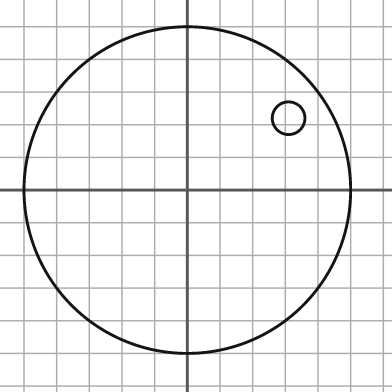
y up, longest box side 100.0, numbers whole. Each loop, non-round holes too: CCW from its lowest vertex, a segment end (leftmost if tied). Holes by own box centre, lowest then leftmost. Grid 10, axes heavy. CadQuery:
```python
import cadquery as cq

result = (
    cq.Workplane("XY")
    .moveTo(0.0, 0.0)
    .circle(50.0)
    .moveTo(31.0, 22.0)
    .circle(5.0)
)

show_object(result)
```